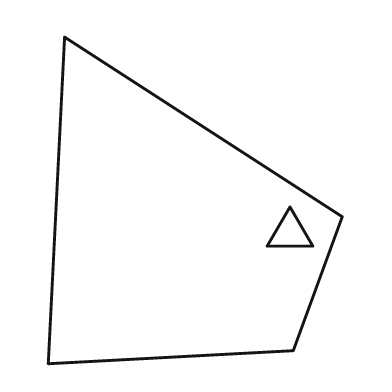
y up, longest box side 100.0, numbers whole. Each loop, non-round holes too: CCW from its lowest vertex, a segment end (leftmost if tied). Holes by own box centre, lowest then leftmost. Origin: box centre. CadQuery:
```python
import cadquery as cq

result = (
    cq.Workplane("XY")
    .moveTo(-45.0, -50.0)
    .lineTo(30.0, -46.0)
    .lineTo(45.0, -5.0)
    .lineTo(-40.0, 50.0)
    .close()
    .moveTo(22.0, -14.0)
    .lineTo(36.0, -14.0)
    .lineTo(29.0, -2.0)
    .close()
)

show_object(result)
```